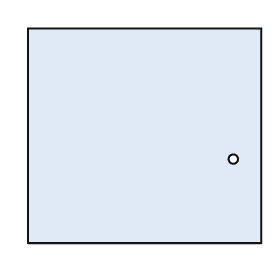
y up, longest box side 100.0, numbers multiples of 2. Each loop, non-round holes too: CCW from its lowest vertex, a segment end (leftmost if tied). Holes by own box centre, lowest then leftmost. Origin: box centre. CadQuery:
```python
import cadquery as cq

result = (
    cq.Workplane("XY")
    .moveTo(-50.0, -46.0)
    .lineTo(50.0, -46.0)
    .lineTo(50.0, 46.0)
    .lineTo(-50.0, 46.0)
    .close()
    .moveTo(38.0, -10.0)
    .circle(2.0)
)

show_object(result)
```